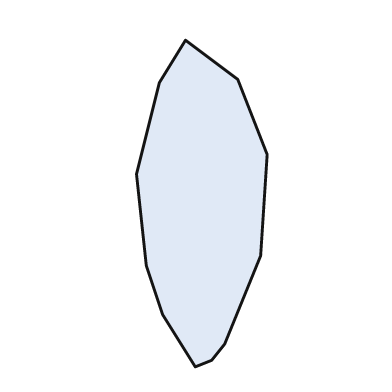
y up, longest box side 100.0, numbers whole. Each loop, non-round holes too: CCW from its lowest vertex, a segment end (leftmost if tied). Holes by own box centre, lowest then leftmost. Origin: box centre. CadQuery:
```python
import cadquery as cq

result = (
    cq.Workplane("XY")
    .moveTo(-2.0, -50.0)
    .lineTo(3.0, -48.0)
    .lineTo(7.0, -43.0)
    .lineTo(18.0, -16.0)
    .lineTo(20.0, 15.0)
    .lineTo(11.0, 38.0)
    .lineTo(-5.0, 50.0)
    .lineTo(-13.0, 37.0)
    .lineTo(-20.0, 9.0)
    .lineTo(-17.0, -19.0)
    .lineTo(-12.0, -34.0)
    .close()
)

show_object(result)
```